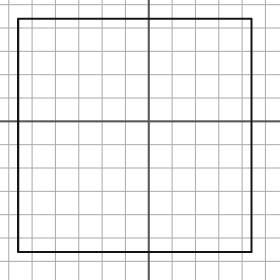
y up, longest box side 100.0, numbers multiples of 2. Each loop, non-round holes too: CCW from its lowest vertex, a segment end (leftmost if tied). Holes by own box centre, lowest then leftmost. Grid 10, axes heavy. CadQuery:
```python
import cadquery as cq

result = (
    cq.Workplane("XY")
    .moveTo(-56.0, -56.0)
    .lineTo(44.0, -56.0)
    .lineTo(44.0, 44.0)
    .lineTo(-56.0, 44.0)
    .close()
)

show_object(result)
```